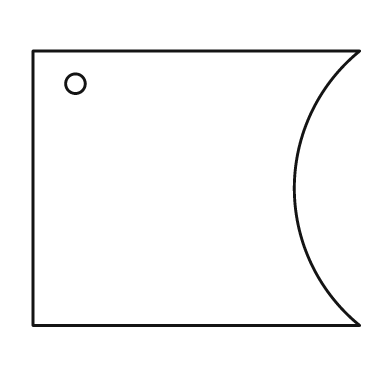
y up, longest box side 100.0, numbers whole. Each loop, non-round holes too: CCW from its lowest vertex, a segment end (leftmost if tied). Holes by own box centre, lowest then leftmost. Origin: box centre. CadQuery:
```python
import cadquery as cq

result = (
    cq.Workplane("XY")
    .moveTo(-50.0, -42.0)
    .lineTo(50.0, -42.0)
    .threePointArc((30.0, 0.0), (50.0, 42.0))
    .lineTo(-50.0, 42.0)
    .close()
    .moveTo(-37.0, 32.0)
    .circle(3.0)
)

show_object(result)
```